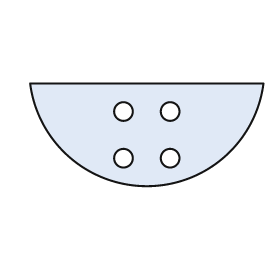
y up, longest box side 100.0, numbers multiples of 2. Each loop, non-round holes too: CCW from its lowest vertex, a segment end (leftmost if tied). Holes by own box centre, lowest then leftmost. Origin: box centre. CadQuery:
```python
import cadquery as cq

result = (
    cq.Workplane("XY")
    .moveTo(-50.0, 22.0)
    .threePointArc((0.0, -22.0), (50.0, 22.0))
    .close()
    .moveTo(-10.0, -10.0)
    .circle(4.0)
    .moveTo(10.0, -10.0)
    .circle(4.0)
    .moveTo(-10.0, 10.0)
    .circle(4.0)
    .moveTo(10.0, 10.0)
    .circle(4.0)
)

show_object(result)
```